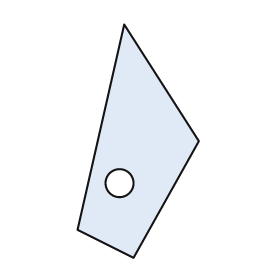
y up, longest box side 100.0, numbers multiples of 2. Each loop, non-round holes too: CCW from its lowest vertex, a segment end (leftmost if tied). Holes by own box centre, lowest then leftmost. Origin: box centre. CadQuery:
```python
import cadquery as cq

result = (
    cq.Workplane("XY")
    .moveTo(-2.0, -50.0)
    .lineTo(26.0, 0.0)
    .lineTo(-6.0, 50.0)
    .lineTo(-26.0, -38.0)
    .close()
    .moveTo(-8.0, -18.0)
    .circle(6.0)
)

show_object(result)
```